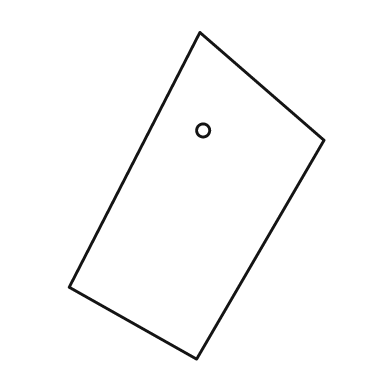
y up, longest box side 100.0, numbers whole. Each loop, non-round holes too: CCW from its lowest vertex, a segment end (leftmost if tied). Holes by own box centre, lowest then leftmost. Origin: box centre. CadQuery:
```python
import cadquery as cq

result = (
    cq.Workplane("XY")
    .moveTo(0.0, -50.0)
    .lineTo(39.0, 17.0)
    .lineTo(1.0, 50.0)
    .lineTo(-39.0, -28.0)
    .close()
    .moveTo(2.0, 20.0)
    .circle(2.0)
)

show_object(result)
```